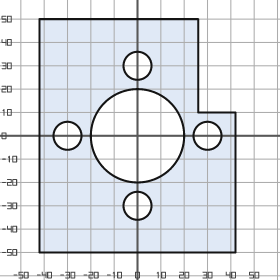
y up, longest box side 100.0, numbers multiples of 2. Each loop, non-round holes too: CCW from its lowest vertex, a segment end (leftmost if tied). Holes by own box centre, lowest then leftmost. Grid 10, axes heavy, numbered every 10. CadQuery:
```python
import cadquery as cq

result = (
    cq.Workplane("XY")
    .moveTo(-42.0, -50.0)
    .lineTo(42.0, -50.0)
    .lineTo(42.0, 10.0)
    .lineTo(26.0, 10.0)
    .lineTo(26.0, 50.0)
    .lineTo(-42.0, 50.0)
    .close()
    .moveTo(0.0, -30.0)
    .circle(6.0)
    .moveTo(-30.0, 0.0)
    .circle(6.0)
    .moveTo(0.0, 0.0)
    .circle(20.0)
    .moveTo(30.0, 0.0)
    .circle(6.0)
    .moveTo(0.0, 30.0)
    .circle(6.0)
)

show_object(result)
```